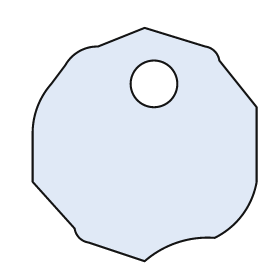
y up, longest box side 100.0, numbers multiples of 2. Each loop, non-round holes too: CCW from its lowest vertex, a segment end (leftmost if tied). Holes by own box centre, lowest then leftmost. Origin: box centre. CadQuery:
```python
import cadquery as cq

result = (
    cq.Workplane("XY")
    .moveTo(0.0, -50.0)
    .threePointArc((14.0, -42.0), (30.0, -40.0))
    .threePointArc((42.0, -30.0), (48.0, -16.0))
    .lineTo(48.0, 16.0)
    .lineTo(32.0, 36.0)
    .threePointArc((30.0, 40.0), (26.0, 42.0))
    .lineTo(0.0, 50.0)
    .lineTo(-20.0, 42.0)
    .threePointArc((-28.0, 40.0), (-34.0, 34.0))
    .lineTo(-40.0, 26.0)
    .threePointArc((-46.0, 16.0), (-48.0, 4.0))
    .lineTo(-48.0, -16.0)
    .lineTo(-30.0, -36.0)
    .threePointArc((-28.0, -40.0), (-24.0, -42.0))
    .close()
    .moveTo(4.0, 26.0)
    .circle(10.0)
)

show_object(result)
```